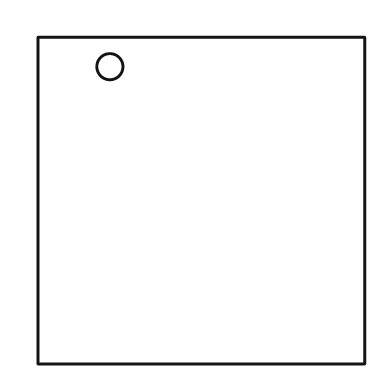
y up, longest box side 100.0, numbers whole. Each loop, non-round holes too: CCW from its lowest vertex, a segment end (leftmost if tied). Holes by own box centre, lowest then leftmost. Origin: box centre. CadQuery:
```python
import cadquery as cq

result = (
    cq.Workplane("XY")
    .moveTo(-50.0, -50.0)
    .lineTo(50.0, -50.0)
    .lineTo(50.0, 50.0)
    .lineTo(-50.0, 50.0)
    .close()
    .moveTo(-28.0, 41.0)
    .circle(4.0)
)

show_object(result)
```